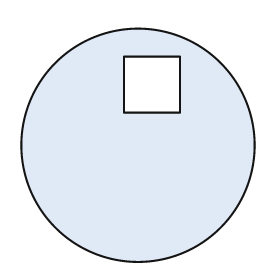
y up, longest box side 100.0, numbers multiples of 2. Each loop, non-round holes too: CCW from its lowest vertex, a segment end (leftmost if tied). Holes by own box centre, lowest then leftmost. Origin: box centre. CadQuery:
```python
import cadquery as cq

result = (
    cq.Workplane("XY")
    .moveTo(0.0, 0.0)
    .circle(50.0)
    .moveTo(-6.0, 14.0)
    .lineTo(18.0, 14.0)
    .lineTo(18.0, 38.0)
    .lineTo(-6.0, 38.0)
    .close()
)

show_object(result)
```